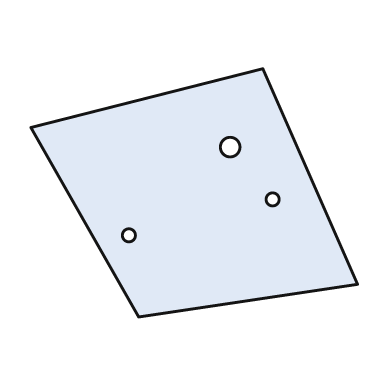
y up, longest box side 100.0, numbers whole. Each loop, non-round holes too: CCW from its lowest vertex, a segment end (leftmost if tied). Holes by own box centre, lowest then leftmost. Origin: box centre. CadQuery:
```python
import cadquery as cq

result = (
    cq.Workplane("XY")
    .moveTo(-17.0, -38.0)
    .lineTo(50.0, -28.0)
    .lineTo(21.0, 38.0)
    .lineTo(-50.0, 20.0)
    .close()
    .moveTo(-20.0, -13.0)
    .circle(2.0)
    .moveTo(24.0, -2.0)
    .circle(2.0)
    .moveTo(11.0, 14.0)
    .circle(3.0)
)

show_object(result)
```